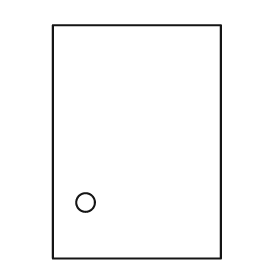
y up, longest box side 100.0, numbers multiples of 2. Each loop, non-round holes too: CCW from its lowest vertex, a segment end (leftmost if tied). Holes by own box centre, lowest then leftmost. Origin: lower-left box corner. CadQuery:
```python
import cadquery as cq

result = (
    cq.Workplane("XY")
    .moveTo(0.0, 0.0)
    .lineTo(72.0, 0.0)
    .lineTo(72.0, 100.0)
    .lineTo(0.0, 100.0)
    .close()
    .moveTo(14.0, 24.0)
    .circle(4.0)
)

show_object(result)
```